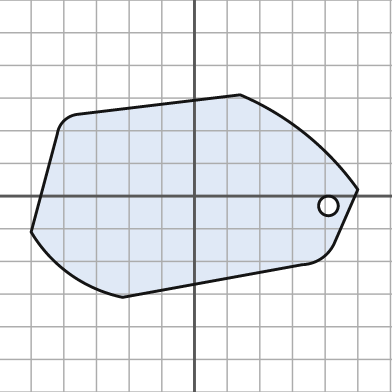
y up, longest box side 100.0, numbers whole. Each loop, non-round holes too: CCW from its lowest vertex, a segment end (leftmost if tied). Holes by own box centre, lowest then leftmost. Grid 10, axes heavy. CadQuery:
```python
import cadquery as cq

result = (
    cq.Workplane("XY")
    .moveTo(-22.0, -31.0)
    .lineTo(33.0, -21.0)
    .threePointArc((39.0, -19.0), (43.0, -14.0))
    .lineTo(50.0, 2.0)
    .threePointArc((34.0, 19.0), (14.0, 31.0))
    .lineTo(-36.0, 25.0)
    .threePointArc((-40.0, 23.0), (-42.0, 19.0))
    .lineTo(-50.0, -11.0)
    .threePointArc((-38.0, -24.0), (-22.0, -31.0))
    .close()
    .moveTo(41.0, -3.0)
    .circle(3.0)
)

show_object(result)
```